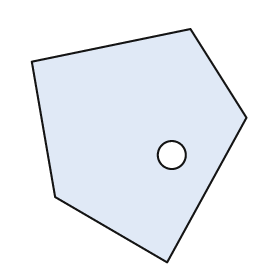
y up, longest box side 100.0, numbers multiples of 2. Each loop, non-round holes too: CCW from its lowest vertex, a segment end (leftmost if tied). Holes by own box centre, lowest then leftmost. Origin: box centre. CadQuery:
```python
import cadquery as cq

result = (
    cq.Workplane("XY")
    .moveTo(12.0, -50.0)
    .lineTo(46.0, 12.0)
    .lineTo(22.0, 50.0)
    .lineTo(-46.0, 36.0)
    .lineTo(-36.0, -22.0)
    .close()
    .moveTo(14.0, -4.0)
    .circle(6.0)
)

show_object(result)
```